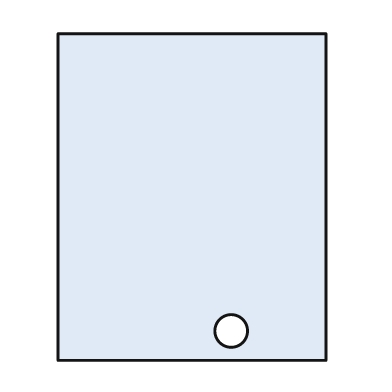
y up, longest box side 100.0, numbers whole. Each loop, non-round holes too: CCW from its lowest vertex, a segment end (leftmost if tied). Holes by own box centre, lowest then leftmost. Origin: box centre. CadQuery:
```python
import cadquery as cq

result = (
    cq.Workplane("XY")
    .moveTo(-41.0, -50.0)
    .lineTo(41.0, -50.0)
    .lineTo(41.0, 50.0)
    .lineTo(-41.0, 50.0)
    .close()
    .moveTo(12.0, -41.0)
    .circle(5.0)
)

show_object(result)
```